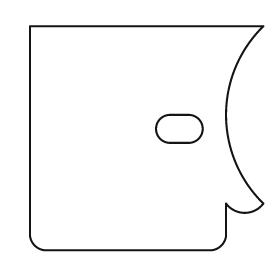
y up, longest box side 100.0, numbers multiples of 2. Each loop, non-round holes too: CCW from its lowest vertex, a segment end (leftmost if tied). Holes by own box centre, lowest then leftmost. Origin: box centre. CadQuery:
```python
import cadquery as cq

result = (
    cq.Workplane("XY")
    .moveTo(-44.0, -48.0)
    .lineTo(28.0, -48.0)
    .threePointArc((32.0, -46.0), (34.0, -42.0))
    .lineTo(34.0, -28.0)
    .threePointArc((42.0, -32.0), (50.0, -28.0))
    .threePointArc((34.0, 10.0), (50.0, 48.0))
    .lineTo(-50.0, 48.0)
    .lineTo(-50.0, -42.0)
    .threePointArc((-48.0, -46.0), (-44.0, -48.0))
    .close()
    .moveTo(10.0, -2.0)
    .lineTo(18.0, -2.0)
    .threePointArc((24.0, 4.0), (18.0, 10.0))
    .lineTo(10.0, 10.0)
    .threePointArc((4.0, 4.0), (10.0, -2.0))
    .close()
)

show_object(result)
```